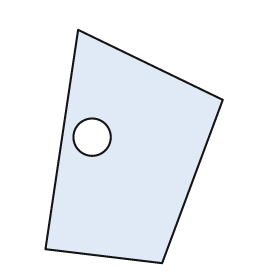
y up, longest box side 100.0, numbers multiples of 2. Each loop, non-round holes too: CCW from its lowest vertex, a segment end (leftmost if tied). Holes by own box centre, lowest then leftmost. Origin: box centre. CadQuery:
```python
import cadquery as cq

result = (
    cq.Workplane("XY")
    .moveTo(12.0, -50.0)
    .lineTo(38.0, 20.0)
    .lineTo(-24.0, 50.0)
    .lineTo(-38.0, -44.0)
    .close()
    .moveTo(-18.0, 4.0)
    .circle(8.0)
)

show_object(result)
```